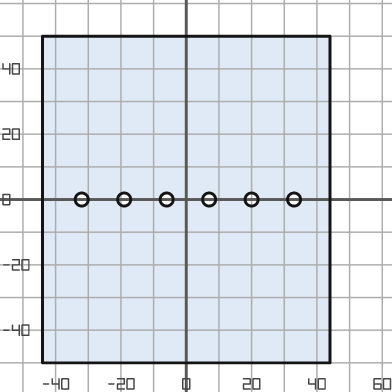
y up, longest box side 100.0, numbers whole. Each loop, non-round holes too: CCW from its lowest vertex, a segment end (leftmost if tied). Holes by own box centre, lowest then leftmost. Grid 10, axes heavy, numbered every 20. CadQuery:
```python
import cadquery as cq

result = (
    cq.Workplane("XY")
    .moveTo(-44.0, -50.0)
    .lineTo(44.0, -50.0)
    .lineTo(44.0, 50.0)
    .lineTo(-44.0, 50.0)
    .close()
    .moveTo(-32.0, 0.0)
    .circle(2.0)
    .moveTo(-19.0, 0.0)
    .circle(2.0)
    .moveTo(-6.0, 0.0)
    .circle(2.0)
    .moveTo(7.0, 0.0)
    .circle(2.0)
    .moveTo(20.0, 0.0)
    .circle(2.0)
    .moveTo(33.0, 0.0)
    .circle(2.0)
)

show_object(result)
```